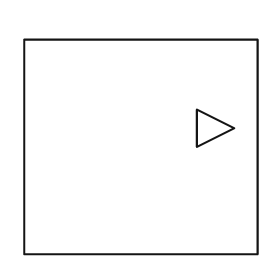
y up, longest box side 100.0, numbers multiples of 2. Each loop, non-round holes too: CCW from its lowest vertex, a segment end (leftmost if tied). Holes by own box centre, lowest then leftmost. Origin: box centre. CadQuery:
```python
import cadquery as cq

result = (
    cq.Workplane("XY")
    .moveTo(-50.0, -46.0)
    .lineTo(50.0, -46.0)
    .lineTo(50.0, 46.0)
    .lineTo(-50.0, 46.0)
    .close()
    .moveTo(24.0, 0.0)
    .lineTo(40.0, 8.0)
    .lineTo(24.0, 16.0)
    .close()
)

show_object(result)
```